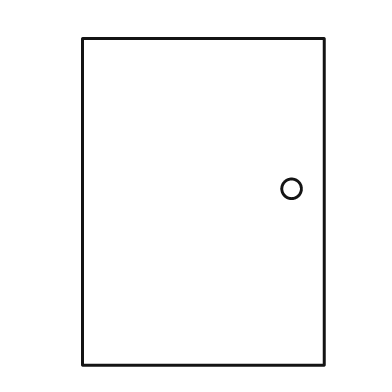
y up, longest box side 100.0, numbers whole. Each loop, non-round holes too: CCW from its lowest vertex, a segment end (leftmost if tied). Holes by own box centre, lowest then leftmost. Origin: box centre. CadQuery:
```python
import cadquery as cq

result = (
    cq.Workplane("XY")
    .moveTo(-37.0, -50.0)
    .lineTo(37.0, -50.0)
    .lineTo(37.0, 50.0)
    .lineTo(-37.0, 50.0)
    .close()
    .moveTo(27.0, 4.0)
    .circle(3.0)
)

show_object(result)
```